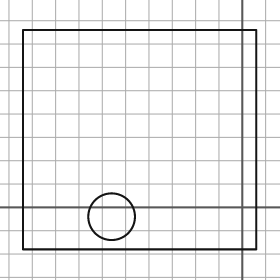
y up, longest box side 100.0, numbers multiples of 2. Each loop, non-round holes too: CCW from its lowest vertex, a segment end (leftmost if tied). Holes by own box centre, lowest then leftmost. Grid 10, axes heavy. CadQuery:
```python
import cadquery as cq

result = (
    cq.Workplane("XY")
    .moveTo(-94.0, -18.0)
    .lineTo(6.0, -18.0)
    .lineTo(6.0, 76.0)
    .lineTo(-94.0, 76.0)
    .close()
    .moveTo(-56.0, -4.0)
    .circle(10.0)
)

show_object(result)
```